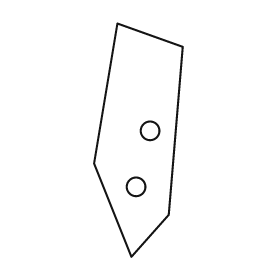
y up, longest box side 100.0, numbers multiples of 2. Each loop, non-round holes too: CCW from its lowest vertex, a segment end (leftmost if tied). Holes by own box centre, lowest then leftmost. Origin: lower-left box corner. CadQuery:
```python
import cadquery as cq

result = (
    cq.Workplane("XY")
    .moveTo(16.0, 0.0)
    .lineTo(32.0, 18.0)
    .lineTo(38.0, 90.0)
    .lineTo(10.0, 100.0)
    .lineTo(0.0, 40.0)
    .close()
    .moveTo(18.0, 30.0)
    .circle(4.0)
    .moveTo(24.0, 54.0)
    .circle(4.0)
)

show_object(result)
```